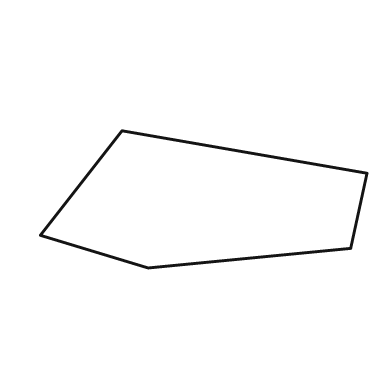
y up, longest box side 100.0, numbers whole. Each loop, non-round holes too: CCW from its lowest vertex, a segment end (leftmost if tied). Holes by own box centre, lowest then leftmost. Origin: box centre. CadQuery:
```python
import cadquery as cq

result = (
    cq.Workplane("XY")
    .moveTo(-17.0, -21.0)
    .lineTo(45.0, -15.0)
    .lineTo(50.0, 8.0)
    .lineTo(-25.0, 21.0)
    .lineTo(-50.0, -11.0)
    .close()
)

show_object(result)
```